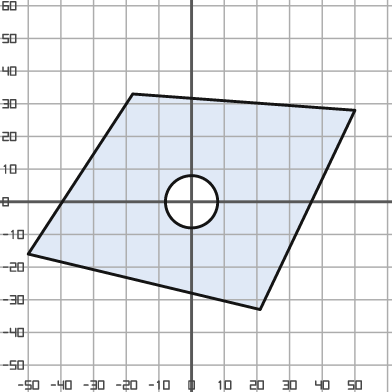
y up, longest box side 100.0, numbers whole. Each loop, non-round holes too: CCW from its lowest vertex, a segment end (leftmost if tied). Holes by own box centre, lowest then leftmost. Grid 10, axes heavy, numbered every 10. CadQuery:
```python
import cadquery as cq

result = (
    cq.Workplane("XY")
    .moveTo(21.0, -33.0)
    .lineTo(50.0, 28.0)
    .lineTo(-18.0, 33.0)
    .lineTo(-50.0, -16.0)
    .close()
    .moveTo(0.0, 0.0)
    .circle(8.0)
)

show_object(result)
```